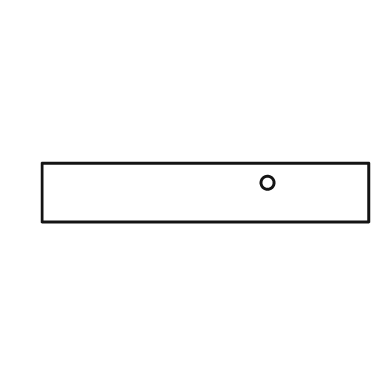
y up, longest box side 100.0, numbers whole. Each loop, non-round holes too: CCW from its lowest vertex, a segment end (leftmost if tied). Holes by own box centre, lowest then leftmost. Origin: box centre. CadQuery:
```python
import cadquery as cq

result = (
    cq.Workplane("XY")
    .moveTo(-50.0, -9.0)
    .lineTo(50.0, -9.0)
    .lineTo(50.0, 9.0)
    .lineTo(-50.0, 9.0)
    .close()
    .moveTo(19.0, 3.0)
    .circle(2.0)
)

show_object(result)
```